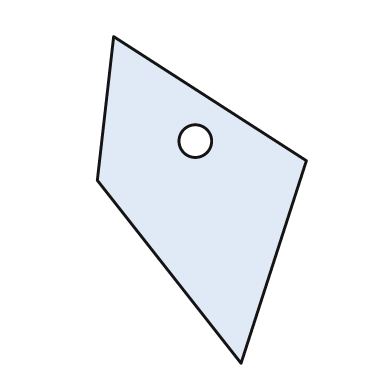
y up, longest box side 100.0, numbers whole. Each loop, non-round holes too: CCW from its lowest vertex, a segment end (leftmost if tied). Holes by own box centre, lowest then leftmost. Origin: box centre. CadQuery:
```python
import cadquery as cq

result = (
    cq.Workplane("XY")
    .moveTo(12.0, -50.0)
    .lineTo(32.0, 12.0)
    .lineTo(-27.0, 50.0)
    .lineTo(-32.0, 6.0)
    .close()
    .moveTo(-2.0, 18.0)
    .circle(5.0)
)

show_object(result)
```